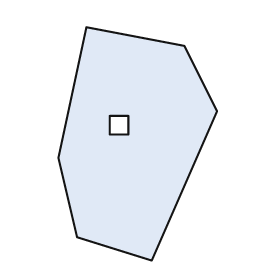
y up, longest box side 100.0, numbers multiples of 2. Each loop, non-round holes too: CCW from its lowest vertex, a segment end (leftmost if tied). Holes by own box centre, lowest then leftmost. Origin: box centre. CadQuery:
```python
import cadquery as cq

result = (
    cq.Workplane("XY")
    .moveTo(6.0, -50.0)
    .lineTo(34.0, 14.0)
    .lineTo(20.0, 42.0)
    .lineTo(-22.0, 50.0)
    .lineTo(-34.0, -6.0)
    .lineTo(-26.0, -40.0)
    .close()
    .moveTo(-12.0, 4.0)
    .lineTo(-4.0, 4.0)
    .lineTo(-4.0, 12.0)
    .lineTo(-12.0, 12.0)
    .close()
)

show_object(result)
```